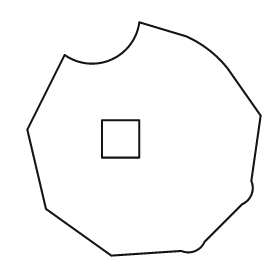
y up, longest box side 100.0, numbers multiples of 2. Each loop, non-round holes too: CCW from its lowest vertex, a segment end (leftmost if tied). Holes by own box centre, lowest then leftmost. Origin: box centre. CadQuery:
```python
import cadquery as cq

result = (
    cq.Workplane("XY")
    .moveTo(-14.0, -50.0)
    .lineTo(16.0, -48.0)
    .threePointArc((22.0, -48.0), (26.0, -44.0))
    .lineTo(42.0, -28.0)
    .threePointArc((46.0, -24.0), (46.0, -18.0))
    .lineTo(50.0, 10.0)
    .lineTo(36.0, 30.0)
    .threePointArc((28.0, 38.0), (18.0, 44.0))
    .lineTo(-2.0, 50.0)
    .threePointArc((-14.0, 34.0), (-34.0, 36.0))
    .lineTo(-50.0, 4.0)
    .lineTo(-42.0, -30.0)
    .close()
    .moveTo(-18.0, -8.0)
    .lineTo(-2.0, -8.0)
    .lineTo(-2.0, 8.0)
    .lineTo(-18.0, 8.0)
    .close()
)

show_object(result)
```